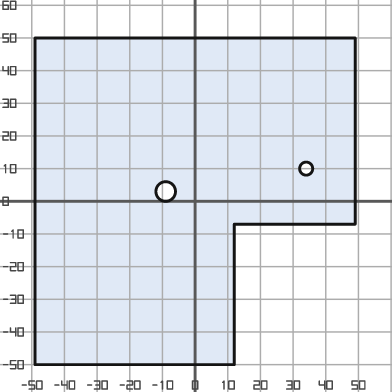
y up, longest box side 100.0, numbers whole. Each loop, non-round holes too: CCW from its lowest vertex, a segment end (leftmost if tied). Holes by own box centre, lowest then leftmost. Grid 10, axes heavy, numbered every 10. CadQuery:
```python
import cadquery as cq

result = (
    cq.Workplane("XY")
    .moveTo(-49.0, -50.0)
    .lineTo(12.0, -50.0)
    .lineTo(12.0, -7.0)
    .lineTo(49.0, -7.0)
    .lineTo(49.0, 50.0)
    .lineTo(-49.0, 50.0)
    .close()
    .moveTo(-9.0, 3.0)
    .circle(3.0)
    .moveTo(34.0, 10.0)
    .circle(2.0)
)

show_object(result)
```